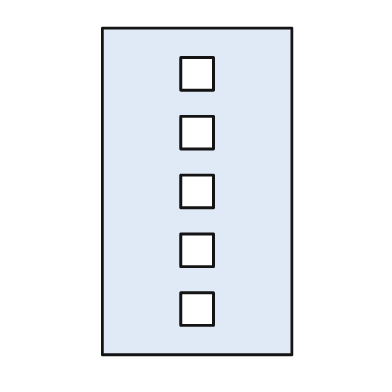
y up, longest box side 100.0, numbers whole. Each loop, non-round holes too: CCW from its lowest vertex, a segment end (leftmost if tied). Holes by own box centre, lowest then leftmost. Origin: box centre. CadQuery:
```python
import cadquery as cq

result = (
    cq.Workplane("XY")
    .moveTo(-29.0, -50.0)
    .lineTo(29.0, -50.0)
    .lineTo(29.0, 50.0)
    .lineTo(-29.0, 50.0)
    .close()
    .moveTo(-5.0, -41.0)
    .lineTo(5.0, -41.0)
    .lineTo(5.0, -31.0)
    .lineTo(-5.0, -31.0)
    .close()
    .moveTo(-5.0, -23.0)
    .lineTo(5.0, -23.0)
    .lineTo(5.0, -13.0)
    .lineTo(-5.0, -13.0)
    .close()
    .moveTo(-5.0, -5.0)
    .lineTo(5.0, -5.0)
    .lineTo(5.0, 5.0)
    .lineTo(-5.0, 5.0)
    .close()
    .moveTo(-5.0, 13.0)
    .lineTo(5.0, 13.0)
    .lineTo(5.0, 23.0)
    .lineTo(-5.0, 23.0)
    .close()
    .moveTo(-5.0, 31.0)
    .lineTo(5.0, 31.0)
    .lineTo(5.0, 41.0)
    .lineTo(-5.0, 41.0)
    .close()
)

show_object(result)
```